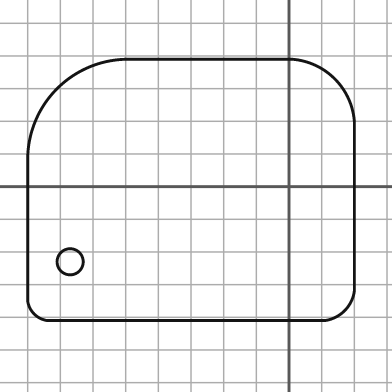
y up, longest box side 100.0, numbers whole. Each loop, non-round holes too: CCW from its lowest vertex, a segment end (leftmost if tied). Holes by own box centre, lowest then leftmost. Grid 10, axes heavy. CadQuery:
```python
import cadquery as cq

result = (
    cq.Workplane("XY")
    .moveTo(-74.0, -41.0)
    .lineTo(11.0, -41.0)
    .threePointArc((17.0, -38.0), (20.0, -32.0))
    .lineTo(20.0, 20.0)
    .threePointArc((14.0, 33.0), (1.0, 39.0))
    .lineTo(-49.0, 39.0)
    .threePointArc((-71.0, 30.0), (-80.0, 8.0))
    .lineTo(-80.0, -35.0)
    .threePointArc((-78.0, -39.0), (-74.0, -41.0))
    .close()
    .moveTo(-67.0, -23.0)
    .circle(4.0)
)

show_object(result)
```